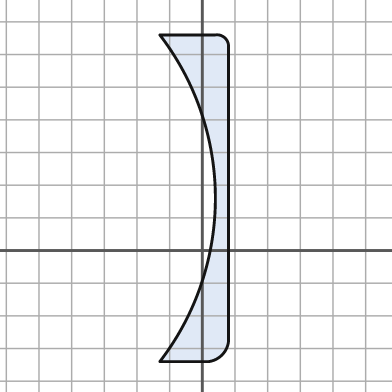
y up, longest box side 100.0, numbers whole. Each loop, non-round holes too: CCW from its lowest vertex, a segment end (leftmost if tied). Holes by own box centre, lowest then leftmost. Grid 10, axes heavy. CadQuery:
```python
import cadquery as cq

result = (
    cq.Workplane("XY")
    .moveTo(-13.0, -34.0)
    .lineTo(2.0, -34.0)
    .threePointArc((6.0, -32.0), (8.0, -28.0))
    .lineTo(8.0, 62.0)
    .threePointArc((7.0, 65.0), (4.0, 66.0))
    .lineTo(-13.0, 66.0)
    .threePointArc((4.0, 16.0), (-13.0, -34.0))
    .close()
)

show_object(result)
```